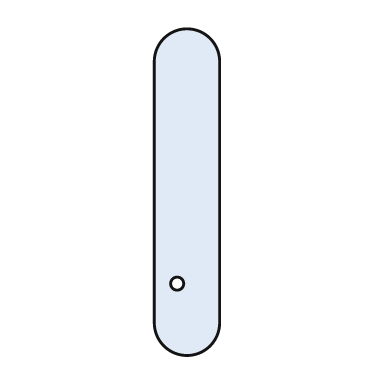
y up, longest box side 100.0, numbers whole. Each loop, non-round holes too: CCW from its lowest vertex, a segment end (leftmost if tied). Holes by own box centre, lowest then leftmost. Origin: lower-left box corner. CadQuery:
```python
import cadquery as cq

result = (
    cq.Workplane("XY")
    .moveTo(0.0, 10.0)
    .threePointArc((10.0, 0.0), (20.0, 10.0))
    .lineTo(20.0, 90.0)
    .threePointArc((10.0, 100.0), (0.0, 90.0))
    .close()
    .moveTo(7.0, 22.0)
    .circle(2.0)
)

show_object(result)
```